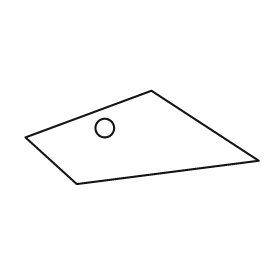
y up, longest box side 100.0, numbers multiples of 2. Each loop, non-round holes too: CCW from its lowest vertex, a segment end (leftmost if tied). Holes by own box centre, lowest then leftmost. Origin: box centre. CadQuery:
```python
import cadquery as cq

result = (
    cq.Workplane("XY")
    .moveTo(-28.0, -20.0)
    .lineTo(50.0, -10.0)
    .lineTo(4.0, 20.0)
    .lineTo(-50.0, 0.0)
    .close()
    .moveTo(-16.0, 4.0)
    .circle(4.0)
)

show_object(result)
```